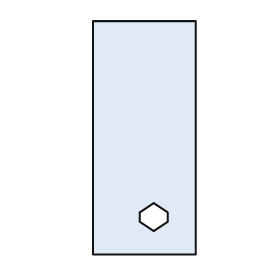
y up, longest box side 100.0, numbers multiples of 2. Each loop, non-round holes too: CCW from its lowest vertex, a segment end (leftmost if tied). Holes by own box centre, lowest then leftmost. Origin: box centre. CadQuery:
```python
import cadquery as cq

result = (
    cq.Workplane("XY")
    .moveTo(-22.0, -50.0)
    .lineTo(22.0, -50.0)
    .lineTo(22.0, 50.0)
    .lineTo(-22.0, 50.0)
    .close()
    .moveTo(4.0, -40.0)
    .lineTo(10.0, -36.0)
    .lineTo(10.0, -32.0)
    .lineTo(4.0, -28.0)
    .lineTo(-2.0, -32.0)
    .lineTo(-2.0, -36.0)
    .close()
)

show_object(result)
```